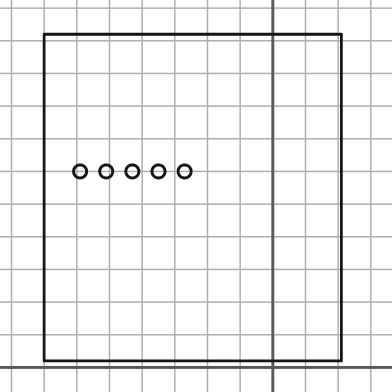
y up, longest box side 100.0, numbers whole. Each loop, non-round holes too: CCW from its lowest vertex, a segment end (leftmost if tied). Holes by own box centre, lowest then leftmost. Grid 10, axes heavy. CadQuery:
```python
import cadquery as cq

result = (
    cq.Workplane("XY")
    .moveTo(-70.0, 2.0)
    .lineTo(21.0, 2.0)
    .lineTo(21.0, 102.0)
    .lineTo(-70.0, 102.0)
    .close()
    .moveTo(-59.0, 60.0)
    .circle(2.0)
    .moveTo(-51.0, 60.0)
    .circle(2.0)
    .moveTo(-43.0, 60.0)
    .circle(2.0)
    .moveTo(-35.0, 60.0)
    .circle(2.0)
    .moveTo(-27.0, 60.0)
    .circle(2.0)
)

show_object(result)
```